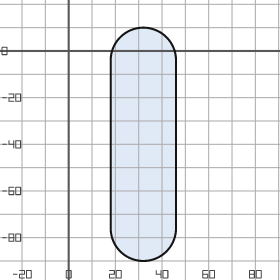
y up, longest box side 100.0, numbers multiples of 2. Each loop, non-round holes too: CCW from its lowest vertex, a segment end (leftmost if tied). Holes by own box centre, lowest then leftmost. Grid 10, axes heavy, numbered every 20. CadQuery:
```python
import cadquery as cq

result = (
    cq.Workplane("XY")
    .moveTo(18.0, -76.0)
    .threePointArc((32.0, -90.0), (46.0, -76.0))
    .lineTo(46.0, -4.0)
    .threePointArc((32.0, 10.0), (18.0, -4.0))
    .close()
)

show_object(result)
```